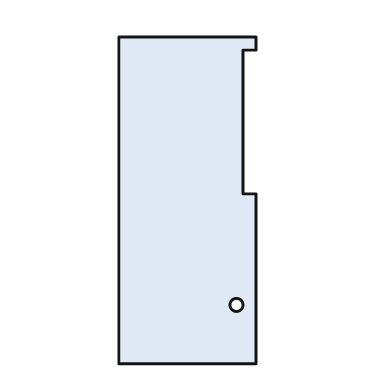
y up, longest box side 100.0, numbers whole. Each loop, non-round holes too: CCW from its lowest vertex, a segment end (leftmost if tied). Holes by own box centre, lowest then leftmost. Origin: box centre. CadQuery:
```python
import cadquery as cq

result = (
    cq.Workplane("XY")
    .moveTo(-21.0, -50.0)
    .lineTo(21.0, -50.0)
    .lineTo(21.0, 2.0)
    .lineTo(17.0, 2.0)
    .lineTo(17.0, 46.0)
    .lineTo(21.0, 46.0)
    .lineTo(21.0, 50.0)
    .lineTo(-21.0, 50.0)
    .close()
    .moveTo(15.0, -32.0)
    .circle(2.0)
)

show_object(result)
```